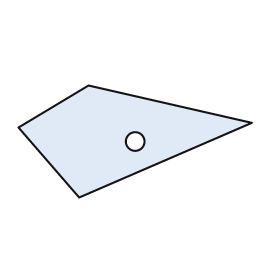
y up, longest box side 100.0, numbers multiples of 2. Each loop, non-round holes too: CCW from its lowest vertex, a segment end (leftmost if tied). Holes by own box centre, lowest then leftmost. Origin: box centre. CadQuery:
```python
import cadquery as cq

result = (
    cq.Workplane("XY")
    .moveTo(-24.0, -24.0)
    .lineTo(50.0, 8.0)
    .lineTo(-20.0, 24.0)
    .lineTo(-50.0, 6.0)
    .close()
    .moveTo(0.0, 0.0)
    .circle(4.0)
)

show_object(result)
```